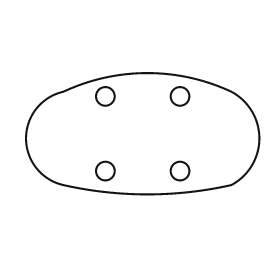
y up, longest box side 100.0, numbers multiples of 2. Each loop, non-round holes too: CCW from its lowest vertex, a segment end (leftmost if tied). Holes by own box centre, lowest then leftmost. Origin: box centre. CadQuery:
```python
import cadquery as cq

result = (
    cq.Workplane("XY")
    .moveTo(-34.0, -22.0)
    .threePointArc((2.0, -26.0), (38.0, -22.0))
    .threePointArc((50.0, -2.0), (38.0, 18.0))
    .threePointArc((2.0, 26.0), (-34.0, 18.0))
    .threePointArc((-50.0, -2.0), (-34.0, -22.0))
    .close()
    .moveTo(-16.0, -16.0)
    .circle(4.0)
    .moveTo(16.0, -16.0)
    .circle(4.0)
    .moveTo(-16.0, 16.0)
    .circle(4.0)
    .moveTo(16.0, 16.0)
    .circle(4.0)
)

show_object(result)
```